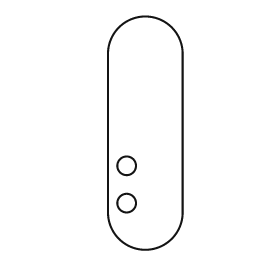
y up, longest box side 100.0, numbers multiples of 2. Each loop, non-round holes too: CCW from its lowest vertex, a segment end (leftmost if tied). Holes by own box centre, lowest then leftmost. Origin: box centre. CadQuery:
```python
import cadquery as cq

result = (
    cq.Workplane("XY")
    .moveTo(-16.0, -34.0)
    .threePointArc((0.0, -50.0), (16.0, -34.0))
    .lineTo(16.0, 34.0)
    .threePointArc((0.0, 50.0), (-16.0, 34.0))
    .close()
    .moveTo(-8.0, -30.0)
    .circle(4.0)
    .moveTo(-8.0, -14.0)
    .circle(4.0)
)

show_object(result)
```